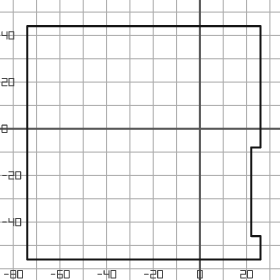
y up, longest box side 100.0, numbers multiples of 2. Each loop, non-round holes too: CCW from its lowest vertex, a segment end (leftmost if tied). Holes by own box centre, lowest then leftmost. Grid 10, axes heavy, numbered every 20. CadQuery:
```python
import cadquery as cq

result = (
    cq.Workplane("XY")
    .moveTo(-74.0, -56.0)
    .lineTo(26.0, -56.0)
    .lineTo(26.0, -46.0)
    .lineTo(22.0, -46.0)
    .lineTo(22.0, -8.0)
    .lineTo(26.0, -8.0)
    .lineTo(26.0, 44.0)
    .lineTo(-74.0, 44.0)
    .close()
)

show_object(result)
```